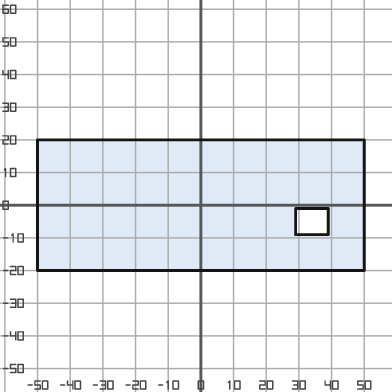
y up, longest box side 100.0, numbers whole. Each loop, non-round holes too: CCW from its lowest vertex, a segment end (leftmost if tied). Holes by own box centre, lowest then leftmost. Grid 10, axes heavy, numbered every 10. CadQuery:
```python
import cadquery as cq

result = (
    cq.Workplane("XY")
    .moveTo(-50.0, -20.0)
    .lineTo(50.0, -20.0)
    .lineTo(50.0, 20.0)
    .lineTo(-50.0, 20.0)
    .close()
    .moveTo(29.0, -9.0)
    .lineTo(39.0, -9.0)
    .lineTo(39.0, -1.0)
    .lineTo(29.0, -1.0)
    .close()
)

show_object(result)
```